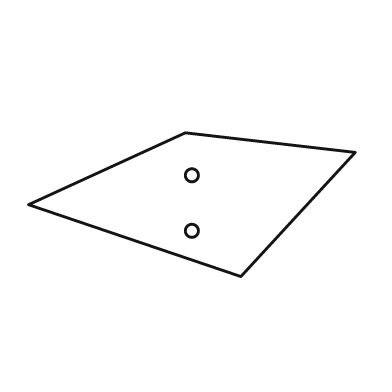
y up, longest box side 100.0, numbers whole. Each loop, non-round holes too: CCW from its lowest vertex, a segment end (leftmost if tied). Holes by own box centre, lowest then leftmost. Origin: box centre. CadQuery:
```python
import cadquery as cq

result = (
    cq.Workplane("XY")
    .moveTo(15.0, -22.0)
    .lineTo(50.0, 16.0)
    .lineTo(-2.0, 22.0)
    .lineTo(-50.0, 0.0)
    .close()
    .moveTo(0.0, -8.0)
    .circle(2.0)
    .moveTo(0.0, 9.0)
    .circle(2.0)
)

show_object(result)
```